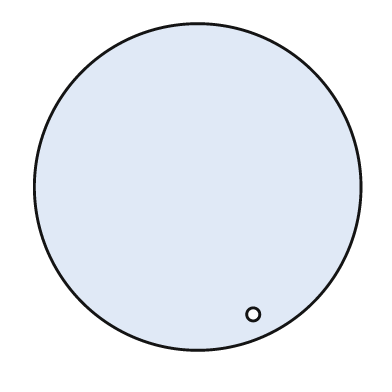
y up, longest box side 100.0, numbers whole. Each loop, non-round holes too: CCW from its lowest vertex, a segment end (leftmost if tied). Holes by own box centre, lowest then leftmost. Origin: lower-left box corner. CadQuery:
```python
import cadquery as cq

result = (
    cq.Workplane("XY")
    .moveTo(50.0, 50.0)
    .circle(50.0)
    .moveTo(67.0, 11.0)
    .circle(2.0)
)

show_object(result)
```